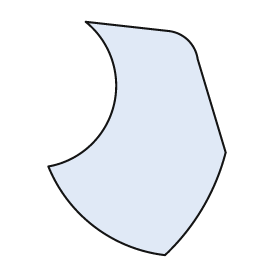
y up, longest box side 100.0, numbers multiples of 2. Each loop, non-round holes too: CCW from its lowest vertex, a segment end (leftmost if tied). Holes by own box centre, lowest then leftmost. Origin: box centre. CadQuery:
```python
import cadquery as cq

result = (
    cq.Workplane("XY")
    .moveTo(12.0, -50.0)
    .threePointArc((28.0, -30.0), (38.0, -6.0))
    .lineTo(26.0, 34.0)
    .threePointArc((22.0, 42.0), (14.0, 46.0))
    .lineTo(-22.0, 50.0)
    .threePointArc((-10.0, 14.0), (-38.0, -12.0))
    .threePointArc((-18.0, -38.0), (12.0, -50.0))
    .close()
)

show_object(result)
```